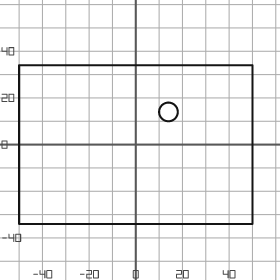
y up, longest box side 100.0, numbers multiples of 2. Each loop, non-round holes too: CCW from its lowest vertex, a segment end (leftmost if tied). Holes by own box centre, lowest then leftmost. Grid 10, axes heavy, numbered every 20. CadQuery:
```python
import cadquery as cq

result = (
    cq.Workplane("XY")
    .moveTo(-50.0, -34.0)
    .lineTo(50.0, -34.0)
    .lineTo(50.0, 34.0)
    .lineTo(-50.0, 34.0)
    .close()
    .moveTo(14.0, 14.0)
    .circle(4.0)
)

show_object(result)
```